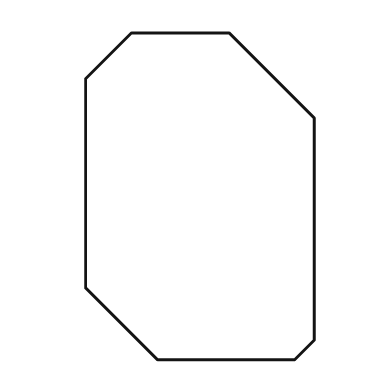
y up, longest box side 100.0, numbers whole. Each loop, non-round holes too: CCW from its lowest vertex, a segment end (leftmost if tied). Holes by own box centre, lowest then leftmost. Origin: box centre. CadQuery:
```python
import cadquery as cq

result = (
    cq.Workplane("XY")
    .moveTo(-13.0, -50.0)
    .lineTo(29.0, -50.0)
    .lineTo(35.0, -44.0)
    .lineTo(35.0, 24.0)
    .lineTo(9.0, 50.0)
    .lineTo(-21.0, 50.0)
    .lineTo(-35.0, 36.0)
    .lineTo(-35.0, -28.0)
    .close()
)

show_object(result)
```